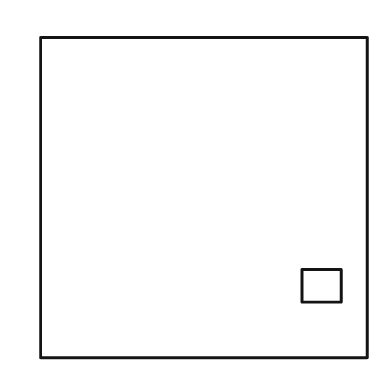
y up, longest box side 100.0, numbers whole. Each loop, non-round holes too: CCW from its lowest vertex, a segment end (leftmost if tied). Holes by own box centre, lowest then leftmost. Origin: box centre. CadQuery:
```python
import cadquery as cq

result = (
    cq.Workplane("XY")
    .moveTo(-50.0, -49.0)
    .lineTo(50.0, -49.0)
    .lineTo(50.0, 49.0)
    .lineTo(-50.0, 49.0)
    .close()
    .moveTo(30.0, -32.0)
    .lineTo(42.0, -32.0)
    .lineTo(42.0, -22.0)
    .lineTo(30.0, -22.0)
    .close()
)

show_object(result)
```